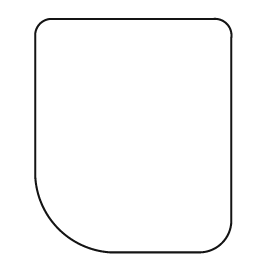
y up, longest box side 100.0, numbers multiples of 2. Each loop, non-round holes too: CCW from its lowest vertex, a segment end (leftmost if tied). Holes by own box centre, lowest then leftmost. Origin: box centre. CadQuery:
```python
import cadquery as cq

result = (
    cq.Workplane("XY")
    .moveTo(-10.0, -50.0)
    .lineTo(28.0, -50.0)
    .threePointArc((38.0, -46.0), (42.0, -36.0))
    .lineTo(42.0, 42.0)
    .threePointArc((40.0, 48.0), (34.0, 50.0))
    .lineTo(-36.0, 50.0)
    .threePointArc((-40.0, 48.0), (-42.0, 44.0))
    .lineTo(-42.0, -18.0)
    .threePointArc((-32.0, -40.0), (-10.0, -50.0))
    .close()
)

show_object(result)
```